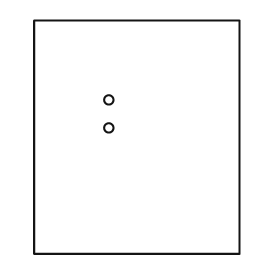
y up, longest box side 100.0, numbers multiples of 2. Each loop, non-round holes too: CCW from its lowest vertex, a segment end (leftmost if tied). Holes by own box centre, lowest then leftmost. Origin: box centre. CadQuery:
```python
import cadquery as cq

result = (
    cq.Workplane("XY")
    .moveTo(-44.0, -50.0)
    .lineTo(44.0, -50.0)
    .lineTo(44.0, 50.0)
    .lineTo(-44.0, 50.0)
    .close()
    .moveTo(-12.0, 4.0)
    .circle(2.0)
    .moveTo(-12.0, 16.0)
    .circle(2.0)
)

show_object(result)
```